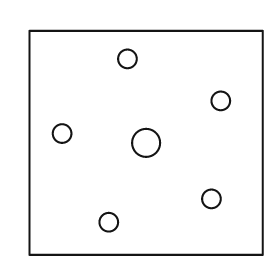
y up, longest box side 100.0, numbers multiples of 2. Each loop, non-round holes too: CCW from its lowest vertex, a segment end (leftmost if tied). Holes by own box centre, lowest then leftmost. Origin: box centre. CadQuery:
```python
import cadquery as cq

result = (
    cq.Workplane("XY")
    .moveTo(-50.0, -48.0)
    .lineTo(50.0, -48.0)
    .lineTo(50.0, 48.0)
    .lineTo(-50.0, 48.0)
    .close()
    .moveTo(-16.0, -34.0)
    .circle(4.0)
    .moveTo(28.0, -24.0)
    .circle(4.0)
    .moveTo(0.0, 0.0)
    .circle(6.0)
    .moveTo(-36.0, 4.0)
    .circle(4.0)
    .moveTo(32.0, 18.0)
    .circle(4.0)
    .moveTo(-8.0, 36.0)
    .circle(4.0)
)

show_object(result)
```